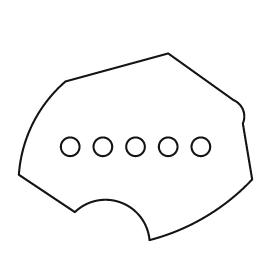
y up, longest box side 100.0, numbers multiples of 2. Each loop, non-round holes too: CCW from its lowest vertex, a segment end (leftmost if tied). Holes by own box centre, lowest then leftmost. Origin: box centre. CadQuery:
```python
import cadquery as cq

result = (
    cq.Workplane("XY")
    .moveTo(6.0, -40.0)
    .threePointArc((30.0, -30.0), (50.0, -14.0))
    .lineTo(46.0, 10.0)
    .threePointArc((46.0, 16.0), (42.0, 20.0))
    .lineTo(14.0, 40.0)
    .lineTo(-30.0, 28.0)
    .threePointArc((-44.0, 10.0), (-50.0, -12.0))
    .lineTo(-26.0, -28.0)
    .threePointArc((-6.0, -24.0), (6.0, -40.0))
    .close()
    .moveTo(-28.0, 0.0)
    .circle(4.0)
    .moveTo(-14.0, 0.0)
    .circle(4.0)
    .moveTo(0.0, 0.0)
    .circle(4.0)
    .moveTo(14.0, 0.0)
    .circle(4.0)
    .moveTo(28.0, 0.0)
    .circle(4.0)
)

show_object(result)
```